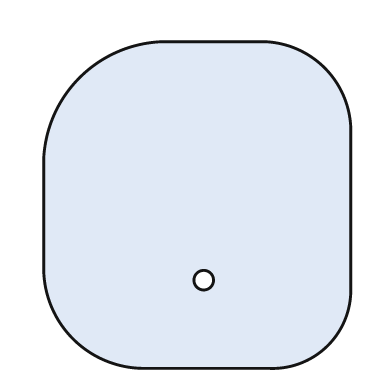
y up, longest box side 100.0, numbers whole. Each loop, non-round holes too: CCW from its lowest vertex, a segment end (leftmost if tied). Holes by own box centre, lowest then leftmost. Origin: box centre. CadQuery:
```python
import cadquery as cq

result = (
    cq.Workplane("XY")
    .moveTo(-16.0, -50.0)
    .lineTo(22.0, -50.0)
    .threePointArc((40.0, -43.0), (47.0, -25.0))
    .lineTo(47.0, 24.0)
    .threePointArc((39.0, 42.0), (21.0, 50.0))
    .lineTo(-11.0, 50.0)
    .threePointArc((-36.0, 39.0), (-47.0, 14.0))
    .lineTo(-47.0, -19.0)
    .threePointArc((-38.0, -41.0), (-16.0, -50.0))
    .close()
    .moveTo(2.0, -23.0)
    .circle(3.0)
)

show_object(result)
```